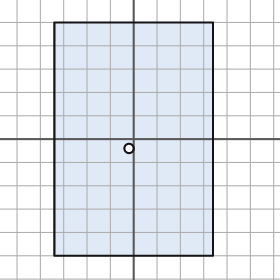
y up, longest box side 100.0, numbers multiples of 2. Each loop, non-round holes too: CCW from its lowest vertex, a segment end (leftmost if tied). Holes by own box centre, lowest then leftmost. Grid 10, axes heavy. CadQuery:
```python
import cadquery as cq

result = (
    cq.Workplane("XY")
    .moveTo(-34.0, -50.0)
    .lineTo(34.0, -50.0)
    .lineTo(34.0, 50.0)
    .lineTo(-34.0, 50.0)
    .close()
    .moveTo(-2.0, -4.0)
    .circle(2.0)
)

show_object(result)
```